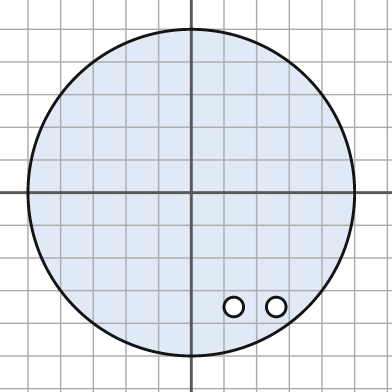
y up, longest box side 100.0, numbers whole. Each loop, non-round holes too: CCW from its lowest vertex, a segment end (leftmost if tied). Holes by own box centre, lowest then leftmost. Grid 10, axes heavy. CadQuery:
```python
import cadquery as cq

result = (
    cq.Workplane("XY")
    .moveTo(0.0, 0.0)
    .circle(50.0)
    .moveTo(13.0, -35.0)
    .circle(3.0)
    .moveTo(26.0, -35.0)
    .circle(3.0)
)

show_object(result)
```